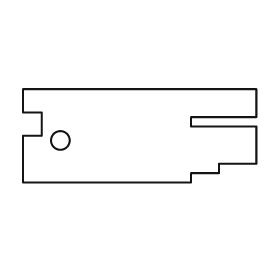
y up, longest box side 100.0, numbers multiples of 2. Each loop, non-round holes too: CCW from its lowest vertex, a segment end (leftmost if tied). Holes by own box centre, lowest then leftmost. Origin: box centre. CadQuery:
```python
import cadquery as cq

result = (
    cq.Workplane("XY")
    .moveTo(-50.0, -20.0)
    .lineTo(22.0, -20.0)
    .lineTo(22.0, -16.0)
    .lineTo(34.0, -16.0)
    .lineTo(34.0, -12.0)
    .lineTo(50.0, -12.0)
    .lineTo(50.0, 4.0)
    .lineTo(22.0, 4.0)
    .lineTo(22.0, 8.0)
    .lineTo(50.0, 8.0)
    .lineTo(50.0, 20.0)
    .lineTo(-50.0, 20.0)
    .lineTo(-50.0, 10.0)
    .lineTo(-42.0, 10.0)
    .lineTo(-42.0, 0.0)
    .lineTo(-50.0, 0.0)
    .close()
    .moveTo(-34.0, -2.0)
    .circle(4.0)
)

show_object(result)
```